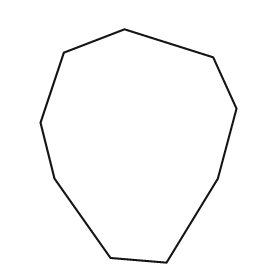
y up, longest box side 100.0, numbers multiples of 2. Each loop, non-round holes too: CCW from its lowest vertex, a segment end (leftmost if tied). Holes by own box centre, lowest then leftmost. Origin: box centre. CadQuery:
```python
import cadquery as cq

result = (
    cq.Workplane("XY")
    .moveTo(12.0, -50.0)
    .lineTo(34.0, -14.0)
    .lineTo(42.0, 16.0)
    .lineTo(32.0, 38.0)
    .lineTo(-6.0, 50.0)
    .lineTo(-32.0, 40.0)
    .lineTo(-42.0, 10.0)
    .lineTo(-36.0, -14.0)
    .lineTo(-12.0, -48.0)
    .close()
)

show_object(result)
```